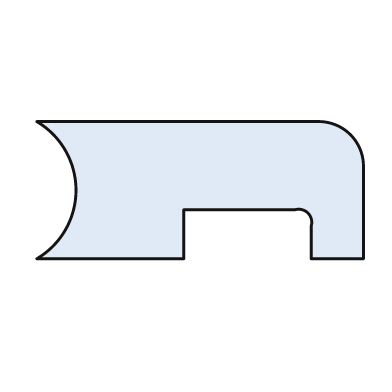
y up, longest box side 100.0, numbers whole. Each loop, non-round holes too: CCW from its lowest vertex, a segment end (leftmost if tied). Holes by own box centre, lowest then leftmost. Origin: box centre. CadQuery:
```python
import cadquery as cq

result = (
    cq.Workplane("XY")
    .moveTo(-50.0, -21.0)
    .lineTo(-5.0, -21.0)
    .lineTo(-5.0, -6.0)
    .lineTo(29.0, -6.0)
    .threePointArc((33.0, -7.0), (34.0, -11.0))
    .lineTo(34.0, -21.0)
    .lineTo(50.0, -21.0)
    .lineTo(50.0, 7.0)
    .threePointArc((46.0, 17.0), (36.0, 21.0))
    .lineTo(-50.0, 21.0)
    .threePointArc((-38.0, 0.0), (-50.0, -21.0))
    .close()
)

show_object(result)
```